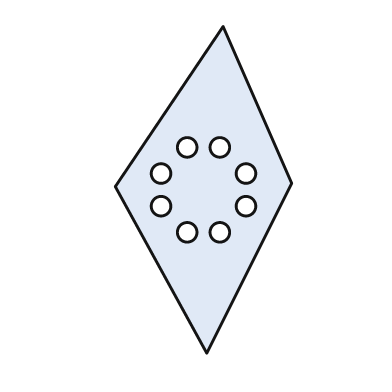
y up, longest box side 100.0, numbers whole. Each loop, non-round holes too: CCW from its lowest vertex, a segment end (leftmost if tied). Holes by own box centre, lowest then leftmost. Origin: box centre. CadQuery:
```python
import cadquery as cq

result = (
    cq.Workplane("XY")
    .moveTo(1.0, -50.0)
    .lineTo(27.0, 2.0)
    .lineTo(6.0, 50.0)
    .lineTo(-27.0, 1.0)
    .close()
    .moveTo(-5.0, -13.0)
    .circle(3.0)
    .moveTo(5.0, -13.0)
    .circle(3.0)
    .moveTo(-13.0, -5.0)
    .circle(3.0)
    .moveTo(13.0, -5.0)
    .circle(3.0)
    .moveTo(-13.0, 5.0)
    .circle(3.0)
    .moveTo(13.0, 5.0)
    .circle(3.0)
    .moveTo(-5.0, 13.0)
    .circle(3.0)
    .moveTo(5.0, 13.0)
    .circle(3.0)
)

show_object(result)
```